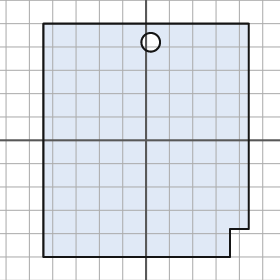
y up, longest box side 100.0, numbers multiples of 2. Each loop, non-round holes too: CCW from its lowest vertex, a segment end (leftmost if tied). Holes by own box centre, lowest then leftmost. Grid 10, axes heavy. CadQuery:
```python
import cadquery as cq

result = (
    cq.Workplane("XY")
    .moveTo(-44.0, -50.0)
    .lineTo(36.0, -50.0)
    .lineTo(36.0, -38.0)
    .lineTo(44.0, -38.0)
    .lineTo(44.0, 50.0)
    .lineTo(-44.0, 50.0)
    .close()
    .moveTo(2.0, 42.0)
    .circle(4.0)
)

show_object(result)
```